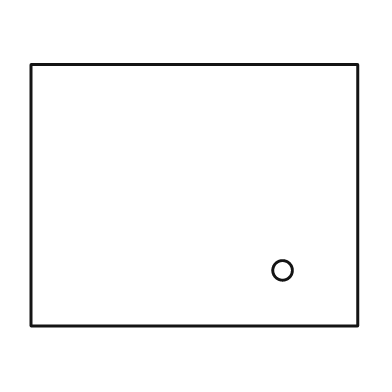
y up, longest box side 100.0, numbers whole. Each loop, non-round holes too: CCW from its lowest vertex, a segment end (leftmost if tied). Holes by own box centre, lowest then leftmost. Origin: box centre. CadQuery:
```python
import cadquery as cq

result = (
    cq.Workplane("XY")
    .moveTo(-50.0, -40.0)
    .lineTo(50.0, -40.0)
    .lineTo(50.0, 40.0)
    .lineTo(-50.0, 40.0)
    .close()
    .moveTo(27.0, -23.0)
    .circle(3.0)
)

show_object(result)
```